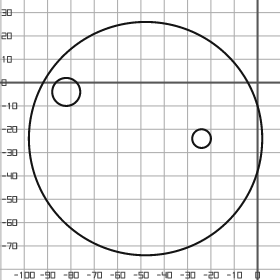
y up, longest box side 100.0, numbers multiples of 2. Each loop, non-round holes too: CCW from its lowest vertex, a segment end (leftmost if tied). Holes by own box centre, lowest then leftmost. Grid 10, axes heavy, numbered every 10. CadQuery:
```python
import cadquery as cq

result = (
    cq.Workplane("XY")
    .moveTo(-48.0, -24.0)
    .circle(50.0)
    .moveTo(-24.0, -24.0)
    .circle(4.0)
    .moveTo(-82.0, -4.0)
    .circle(6.0)
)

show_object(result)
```